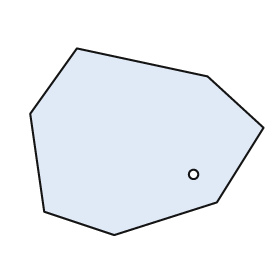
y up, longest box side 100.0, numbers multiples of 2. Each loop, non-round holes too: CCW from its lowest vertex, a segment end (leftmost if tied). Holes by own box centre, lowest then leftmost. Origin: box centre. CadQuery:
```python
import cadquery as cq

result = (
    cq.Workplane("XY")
    .moveTo(-14.0, -40.0)
    .lineTo(30.0, -26.0)
    .lineTo(50.0, 6.0)
    .lineTo(26.0, 28.0)
    .lineTo(-30.0, 40.0)
    .lineTo(-50.0, 12.0)
    .lineTo(-44.0, -30.0)
    .close()
    .moveTo(20.0, -14.0)
    .circle(2.0)
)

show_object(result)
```